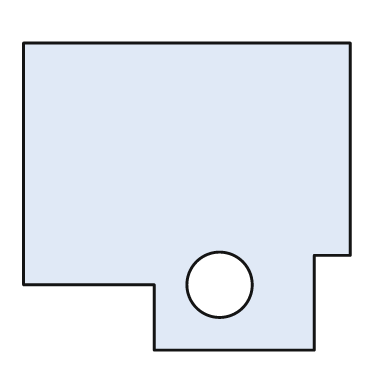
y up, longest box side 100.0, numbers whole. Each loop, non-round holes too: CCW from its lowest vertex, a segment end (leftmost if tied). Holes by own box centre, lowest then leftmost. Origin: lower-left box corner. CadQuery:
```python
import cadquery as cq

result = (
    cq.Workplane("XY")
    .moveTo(40.0, 0.0)
    .lineTo(89.0, 0.0)
    .lineTo(89.0, 29.0)
    .lineTo(100.0, 29.0)
    .lineTo(100.0, 94.0)
    .lineTo(0.0, 94.0)
    .lineTo(0.0, 20.0)
    .lineTo(40.0, 20.0)
    .close()
    .moveTo(60.0, 20.0)
    .circle(10.0)
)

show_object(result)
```